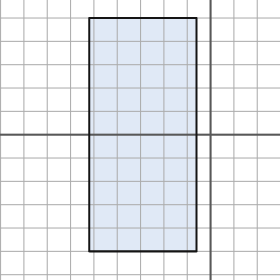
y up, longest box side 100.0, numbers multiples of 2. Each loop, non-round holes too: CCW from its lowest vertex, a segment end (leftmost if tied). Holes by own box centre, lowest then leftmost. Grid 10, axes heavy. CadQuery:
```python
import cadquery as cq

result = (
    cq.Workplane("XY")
    .moveTo(-52.0, -50.0)
    .lineTo(-6.0, -50.0)
    .lineTo(-6.0, 50.0)
    .lineTo(-52.0, 50.0)
    .close()
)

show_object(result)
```